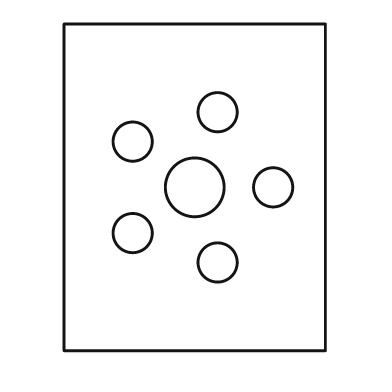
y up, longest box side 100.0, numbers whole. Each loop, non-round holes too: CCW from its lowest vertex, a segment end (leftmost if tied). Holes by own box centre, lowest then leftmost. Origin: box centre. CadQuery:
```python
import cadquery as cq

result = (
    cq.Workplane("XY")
    .moveTo(-40.0, -50.0)
    .lineTo(40.0, -50.0)
    .lineTo(40.0, 50.0)
    .lineTo(-40.0, 50.0)
    .close()
    .moveTo(7.0, -23.0)
    .circle(6.0)
    .moveTo(-19.0, -14.0)
    .circle(6.0)
    .moveTo(0.0, 0.0)
    .circle(9.0)
    .moveTo(24.0, 0.0)
    .circle(6.0)
    .moveTo(-19.0, 14.0)
    .circle(6.0)
    .moveTo(7.0, 23.0)
    .circle(6.0)
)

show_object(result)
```